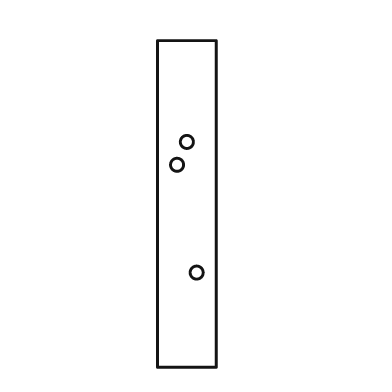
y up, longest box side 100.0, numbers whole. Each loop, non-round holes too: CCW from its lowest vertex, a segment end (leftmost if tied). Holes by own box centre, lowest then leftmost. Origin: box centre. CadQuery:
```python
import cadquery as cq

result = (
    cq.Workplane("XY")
    .moveTo(-9.0, -50.0)
    .lineTo(9.0, -50.0)
    .lineTo(9.0, 50.0)
    .lineTo(-9.0, 50.0)
    .close()
    .moveTo(3.0, -21.0)
    .circle(2.0)
    .moveTo(-3.0, 12.0)
    .circle(2.0)
    .moveTo(0.0, 19.0)
    .circle(2.0)
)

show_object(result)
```